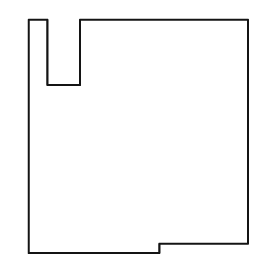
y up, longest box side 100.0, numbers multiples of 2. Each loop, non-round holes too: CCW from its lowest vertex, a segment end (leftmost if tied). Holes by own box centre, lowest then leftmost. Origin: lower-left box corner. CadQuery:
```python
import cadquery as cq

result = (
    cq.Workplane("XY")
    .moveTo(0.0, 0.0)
    .lineTo(56.0, 0.0)
    .lineTo(56.0, 4.0)
    .lineTo(94.0, 4.0)
    .lineTo(94.0, 100.0)
    .lineTo(22.0, 100.0)
    .lineTo(22.0, 72.0)
    .lineTo(8.0, 72.0)
    .lineTo(8.0, 100.0)
    .lineTo(0.0, 100.0)
    .close()
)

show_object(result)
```